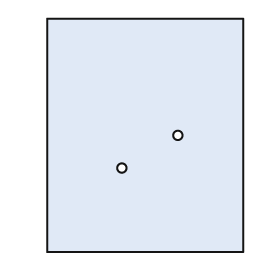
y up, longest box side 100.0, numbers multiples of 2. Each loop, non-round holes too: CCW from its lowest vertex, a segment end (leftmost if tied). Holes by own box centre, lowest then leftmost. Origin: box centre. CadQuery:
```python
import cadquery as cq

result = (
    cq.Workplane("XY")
    .moveTo(-42.0, -50.0)
    .lineTo(42.0, -50.0)
    .lineTo(42.0, 50.0)
    .lineTo(-42.0, 50.0)
    .close()
    .moveTo(-10.0, -14.0)
    .circle(2.0)
    .moveTo(14.0, 0.0)
    .circle(2.0)
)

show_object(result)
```